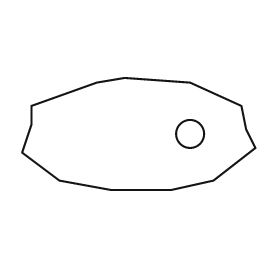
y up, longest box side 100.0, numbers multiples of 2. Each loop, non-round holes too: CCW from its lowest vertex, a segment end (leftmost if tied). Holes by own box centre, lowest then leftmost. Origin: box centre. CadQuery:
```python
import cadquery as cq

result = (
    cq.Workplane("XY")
    .moveTo(-12.0, -24.0)
    .lineTo(14.0, -24.0)
    .lineTo(32.0, -20.0)
    .lineTo(50.0, -6.0)
    .lineTo(46.0, 2.0)
    .lineTo(44.0, 12.0)
    .lineTo(22.0, 22.0)
    .lineTo(-6.0, 24.0)
    .lineTo(-18.0, 22.0)
    .lineTo(-46.0, 12.0)
    .lineTo(-46.0, 4.0)
    .lineTo(-50.0, -8.0)
    .lineTo(-34.0, -20.0)
    .close()
    .moveTo(22.0, 0.0)
    .circle(6.0)
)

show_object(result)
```